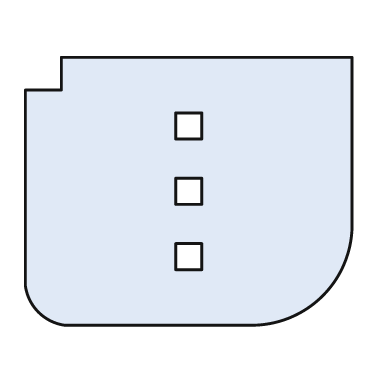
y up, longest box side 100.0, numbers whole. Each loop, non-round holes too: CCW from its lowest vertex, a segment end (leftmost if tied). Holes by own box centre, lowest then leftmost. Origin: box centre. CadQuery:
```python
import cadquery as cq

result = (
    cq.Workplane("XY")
    .moveTo(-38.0, -41.0)
    .lineTo(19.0, -41.0)
    .threePointArc((41.0, -32.0), (50.0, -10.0))
    .lineTo(50.0, 41.0)
    .lineTo(-39.0, 41.0)
    .lineTo(-39.0, 31.0)
    .lineTo(-50.0, 31.0)
    .lineTo(-50.0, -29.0)
    .threePointArc((-46.0, -37.0), (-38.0, -41.0))
    .close()
    .moveTo(-4.0, -24.0)
    .lineTo(4.0, -24.0)
    .lineTo(4.0, -16.0)
    .lineTo(-4.0, -16.0)
    .close()
    .moveTo(-4.0, -4.0)
    .lineTo(4.0, -4.0)
    .lineTo(4.0, 4.0)
    .lineTo(-4.0, 4.0)
    .close()
    .moveTo(-4.0, 16.0)
    .lineTo(4.0, 16.0)
    .lineTo(4.0, 24.0)
    .lineTo(-4.0, 24.0)
    .close()
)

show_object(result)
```